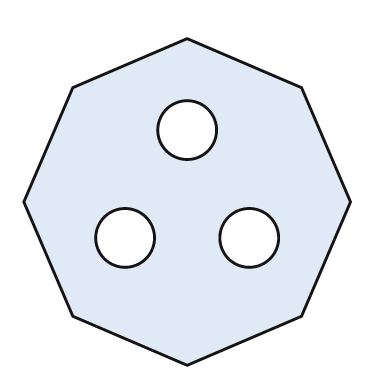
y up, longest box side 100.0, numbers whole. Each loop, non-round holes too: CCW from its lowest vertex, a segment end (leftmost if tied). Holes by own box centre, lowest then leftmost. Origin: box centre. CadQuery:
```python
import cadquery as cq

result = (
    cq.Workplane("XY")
    .moveTo(0.0, -50.0)
    .lineTo(35.0, -35.0)
    .lineTo(50.0, 0.0)
    .lineTo(35.0, 35.0)
    .lineTo(0.0, 50.0)
    .lineTo(-35.0, 35.0)
    .lineTo(-50.0, 0.0)
    .lineTo(-35.0, -35.0)
    .close()
    .moveTo(-19.0, -11.0)
    .circle(9.0)
    .moveTo(19.0, -11.0)
    .circle(9.0)
    .moveTo(0.0, 22.0)
    .circle(9.0)
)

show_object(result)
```